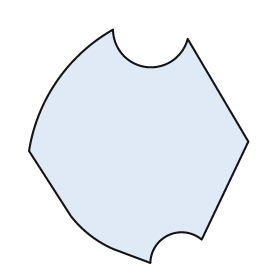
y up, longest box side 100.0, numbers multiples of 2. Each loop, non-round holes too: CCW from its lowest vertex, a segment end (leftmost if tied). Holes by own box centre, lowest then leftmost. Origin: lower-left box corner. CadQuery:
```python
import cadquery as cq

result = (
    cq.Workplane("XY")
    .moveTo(52.0, 0.0)
    .threePointArc((60.0, 12.0), (74.0, 10.0))
    .lineTo(94.0, 52.0)
    .lineTo(68.0, 96.0)
    .threePointArc((50.0, 84.0), (36.0, 100.0))
    .threePointArc((12.0, 78.0), (0.0, 48.0))
    .lineTo(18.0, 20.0)
    .threePointArc((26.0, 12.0), (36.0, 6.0))
    .close()
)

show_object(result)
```